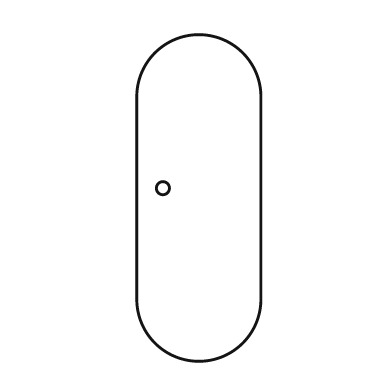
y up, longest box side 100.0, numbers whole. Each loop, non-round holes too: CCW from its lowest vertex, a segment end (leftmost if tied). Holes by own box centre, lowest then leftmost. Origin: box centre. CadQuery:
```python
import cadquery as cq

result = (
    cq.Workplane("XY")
    .moveTo(-19.0, -31.0)
    .threePointArc((0.0, -50.0), (19.0, -31.0))
    .lineTo(19.0, 31.0)
    .threePointArc((0.0, 50.0), (-19.0, 31.0))
    .close()
    .moveTo(-11.0, 3.0)
    .circle(2.0)
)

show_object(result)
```